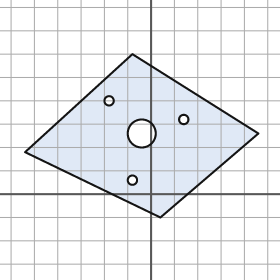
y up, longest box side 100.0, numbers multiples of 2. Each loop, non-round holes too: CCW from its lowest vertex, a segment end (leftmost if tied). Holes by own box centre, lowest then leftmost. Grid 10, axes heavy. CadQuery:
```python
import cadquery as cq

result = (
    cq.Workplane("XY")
    .moveTo(4.0, -10.0)
    .lineTo(46.0, 26.0)
    .lineTo(-8.0, 60.0)
    .lineTo(-54.0, 18.0)
    .close()
    .moveTo(-8.0, 6.0)
    .circle(2.0)
    .moveTo(-4.0, 26.0)
    .circle(6.0)
    .moveTo(14.0, 32.0)
    .circle(2.0)
    .moveTo(-18.0, 40.0)
    .circle(2.0)
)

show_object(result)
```